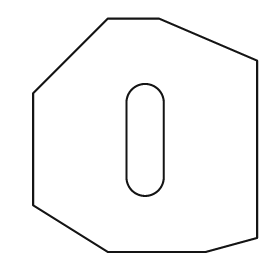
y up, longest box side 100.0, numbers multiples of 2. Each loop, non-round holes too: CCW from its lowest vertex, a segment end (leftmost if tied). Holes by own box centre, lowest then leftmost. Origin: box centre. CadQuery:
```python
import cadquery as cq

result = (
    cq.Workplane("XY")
    .moveTo(-16.0, -50.0)
    .lineTo(26.0, -50.0)
    .lineTo(48.0, -44.0)
    .lineTo(48.0, 32.0)
    .lineTo(6.0, 50.0)
    .lineTo(-16.0, 50.0)
    .lineTo(-48.0, 18.0)
    .lineTo(-48.0, -30.0)
    .close()
    .moveTo(-8.0, -18.0)
    .threePointArc((0.0, -26.0), (8.0, -18.0))
    .lineTo(8.0, 14.0)
    .threePointArc((0.0, 22.0), (-8.0, 14.0))
    .close()
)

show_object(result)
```